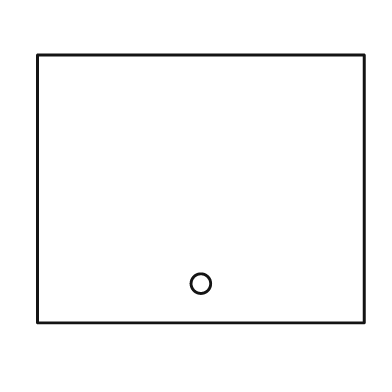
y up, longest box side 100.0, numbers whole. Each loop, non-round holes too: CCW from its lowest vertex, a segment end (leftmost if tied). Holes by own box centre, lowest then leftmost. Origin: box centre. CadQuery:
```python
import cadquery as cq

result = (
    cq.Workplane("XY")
    .moveTo(-50.0, -41.0)
    .lineTo(50.0, -41.0)
    .lineTo(50.0, 41.0)
    .lineTo(-50.0, 41.0)
    .close()
    .moveTo(0.0, -29.0)
    .circle(3.0)
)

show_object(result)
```